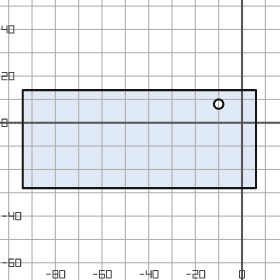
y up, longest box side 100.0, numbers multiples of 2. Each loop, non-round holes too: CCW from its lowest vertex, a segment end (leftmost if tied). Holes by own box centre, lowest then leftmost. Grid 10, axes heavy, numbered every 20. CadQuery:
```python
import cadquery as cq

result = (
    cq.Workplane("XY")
    .moveTo(-94.0, -28.0)
    .lineTo(6.0, -28.0)
    .lineTo(6.0, 14.0)
    .lineTo(-94.0, 14.0)
    .close()
    .moveTo(-10.0, 8.0)
    .circle(2.0)
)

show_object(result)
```